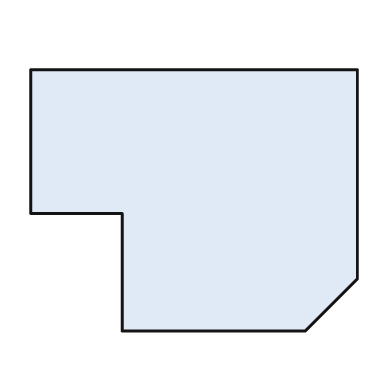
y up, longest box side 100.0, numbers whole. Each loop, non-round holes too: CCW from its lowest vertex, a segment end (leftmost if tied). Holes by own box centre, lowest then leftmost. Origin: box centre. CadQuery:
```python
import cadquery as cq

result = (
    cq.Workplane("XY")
    .moveTo(-22.0, -40.0)
    .lineTo(34.0, -40.0)
    .lineTo(50.0, -24.0)
    .lineTo(50.0, 40.0)
    .lineTo(-50.0, 40.0)
    .lineTo(-50.0, -4.0)
    .lineTo(-22.0, -4.0)
    .close()
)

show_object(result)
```